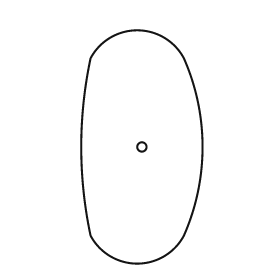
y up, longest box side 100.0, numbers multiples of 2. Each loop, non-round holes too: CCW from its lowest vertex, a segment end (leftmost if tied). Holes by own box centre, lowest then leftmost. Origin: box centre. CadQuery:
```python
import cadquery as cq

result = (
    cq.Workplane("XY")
    .moveTo(-22.0, -38.0)
    .threePointArc((-2.0, -50.0), (18.0, -38.0))
    .threePointArc((26.0, 0.0), (18.0, 38.0))
    .threePointArc((-2.0, 50.0), (-22.0, 38.0))
    .threePointArc((-26.0, 0.0), (-22.0, -38.0))
    .close()
    .moveTo(0.0, 0.0)
    .circle(2.0)
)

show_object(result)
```